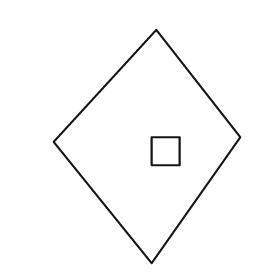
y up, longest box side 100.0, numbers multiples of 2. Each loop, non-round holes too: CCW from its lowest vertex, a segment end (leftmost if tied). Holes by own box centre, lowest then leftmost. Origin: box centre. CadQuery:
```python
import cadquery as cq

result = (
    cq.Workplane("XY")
    .moveTo(2.0, -50.0)
    .lineTo(40.0, 4.0)
    .lineTo(4.0, 50.0)
    .lineTo(-40.0, 2.0)
    .close()
    .moveTo(2.0, -8.0)
    .lineTo(14.0, -8.0)
    .lineTo(14.0, 4.0)
    .lineTo(2.0, 4.0)
    .close()
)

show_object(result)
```